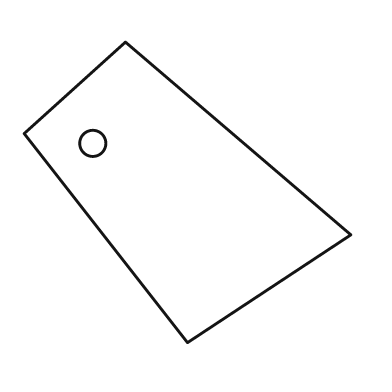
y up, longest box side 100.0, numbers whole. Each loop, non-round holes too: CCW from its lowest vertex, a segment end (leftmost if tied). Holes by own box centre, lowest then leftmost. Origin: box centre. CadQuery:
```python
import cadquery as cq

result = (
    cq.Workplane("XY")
    .moveTo(0.0, -46.0)
    .lineTo(50.0, -13.0)
    .lineTo(-19.0, 46.0)
    .lineTo(-50.0, 18.0)
    .close()
    .moveTo(-29.0, 15.0)
    .circle(4.0)
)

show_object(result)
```